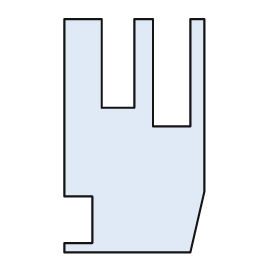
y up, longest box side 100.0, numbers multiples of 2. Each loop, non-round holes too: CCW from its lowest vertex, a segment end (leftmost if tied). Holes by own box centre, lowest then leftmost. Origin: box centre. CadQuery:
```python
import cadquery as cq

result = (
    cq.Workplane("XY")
    .moveTo(-30.0, -50.0)
    .lineTo(24.0, -50.0)
    .lineTo(30.0, -24.0)
    .lineTo(30.0, 50.0)
    .lineTo(24.0, 50.0)
    .lineTo(24.0, 4.0)
    .lineTo(8.0, 4.0)
    .lineTo(8.0, 50.0)
    .lineTo(0.0, 50.0)
    .lineTo(0.0, 12.0)
    .lineTo(-14.0, 12.0)
    .lineTo(-14.0, 50.0)
    .lineTo(-30.0, 50.0)
    .lineTo(-30.0, -26.0)
    .lineTo(-18.0, -26.0)
    .lineTo(-18.0, -46.0)
    .lineTo(-30.0, -46.0)
    .close()
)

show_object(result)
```